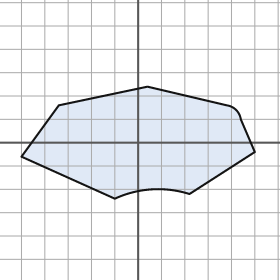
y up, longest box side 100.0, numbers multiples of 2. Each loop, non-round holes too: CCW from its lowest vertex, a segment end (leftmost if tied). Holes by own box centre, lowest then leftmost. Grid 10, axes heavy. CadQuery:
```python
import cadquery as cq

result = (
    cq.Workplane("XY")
    .moveTo(-10.0, -24.0)
    .threePointArc((6.0, -20.0), (22.0, -22.0))
    .lineTo(50.0, -4.0)
    .lineTo(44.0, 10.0)
    .threePointArc((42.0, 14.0), (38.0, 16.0))
    .lineTo(4.0, 24.0)
    .lineTo(-34.0, 16.0)
    .lineTo(-50.0, -6.0)
    .close()
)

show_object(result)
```